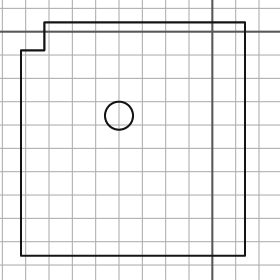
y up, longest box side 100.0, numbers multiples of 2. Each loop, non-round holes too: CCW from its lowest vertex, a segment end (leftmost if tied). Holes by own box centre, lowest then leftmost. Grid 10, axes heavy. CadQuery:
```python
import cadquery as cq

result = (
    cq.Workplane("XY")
    .moveTo(-82.0, -96.0)
    .lineTo(14.0, -96.0)
    .lineTo(14.0, 4.0)
    .lineTo(-72.0, 4.0)
    .lineTo(-72.0, -8.0)
    .lineTo(-82.0, -8.0)
    .close()
    .moveTo(-40.0, -36.0)
    .circle(6.0)
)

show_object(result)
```